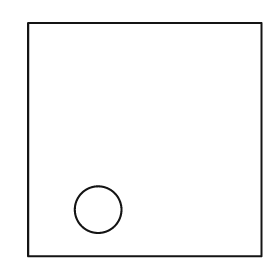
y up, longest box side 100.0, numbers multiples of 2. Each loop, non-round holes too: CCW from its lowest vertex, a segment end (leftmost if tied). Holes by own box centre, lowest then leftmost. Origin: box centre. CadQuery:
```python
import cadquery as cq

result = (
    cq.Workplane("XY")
    .moveTo(-50.0, -50.0)
    .lineTo(50.0, -50.0)
    .lineTo(50.0, 50.0)
    .lineTo(-50.0, 50.0)
    .close()
    .moveTo(-20.0, -30.0)
    .circle(10.0)
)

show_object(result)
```